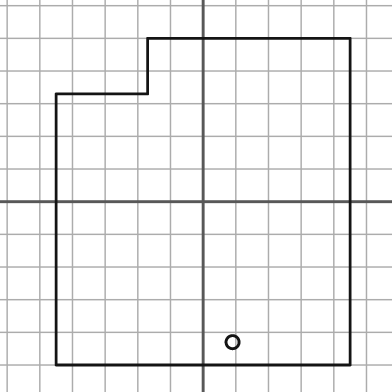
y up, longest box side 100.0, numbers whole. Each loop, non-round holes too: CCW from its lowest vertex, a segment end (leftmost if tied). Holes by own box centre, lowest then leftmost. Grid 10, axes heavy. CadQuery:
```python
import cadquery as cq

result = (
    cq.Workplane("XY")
    .moveTo(-45.0, -50.0)
    .lineTo(45.0, -50.0)
    .lineTo(45.0, 50.0)
    .lineTo(-17.0, 50.0)
    .lineTo(-17.0, 33.0)
    .lineTo(-45.0, 33.0)
    .close()
    .moveTo(9.0, -43.0)
    .circle(2.0)
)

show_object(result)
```